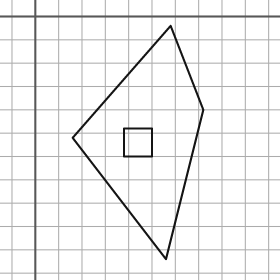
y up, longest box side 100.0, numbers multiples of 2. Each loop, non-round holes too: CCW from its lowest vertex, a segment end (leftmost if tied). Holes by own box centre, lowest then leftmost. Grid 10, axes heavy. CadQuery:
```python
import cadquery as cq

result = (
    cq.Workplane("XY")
    .moveTo(56.0, -104.0)
    .lineTo(72.0, -40.0)
    .lineTo(58.0, -4.0)
    .lineTo(16.0, -52.0)
    .close()
    .moveTo(38.0, -60.0)
    .lineTo(50.0, -60.0)
    .lineTo(50.0, -48.0)
    .lineTo(38.0, -48.0)
    .close()
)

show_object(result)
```